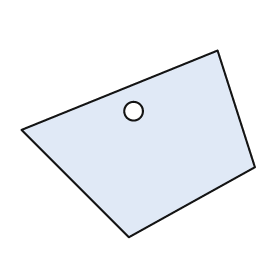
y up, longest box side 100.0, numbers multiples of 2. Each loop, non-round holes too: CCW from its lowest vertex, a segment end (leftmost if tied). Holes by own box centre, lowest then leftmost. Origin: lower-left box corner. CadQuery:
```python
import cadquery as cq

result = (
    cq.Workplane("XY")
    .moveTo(46.0, 0.0)
    .lineTo(100.0, 30.0)
    .lineTo(84.0, 80.0)
    .lineTo(0.0, 46.0)
    .close()
    .moveTo(48.0, 54.0)
    .circle(4.0)
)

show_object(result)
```